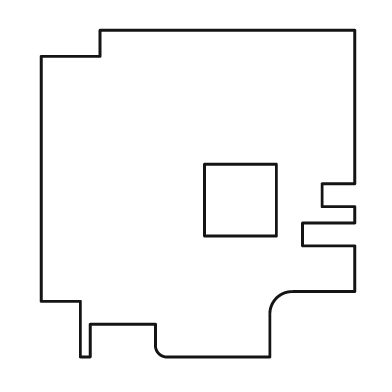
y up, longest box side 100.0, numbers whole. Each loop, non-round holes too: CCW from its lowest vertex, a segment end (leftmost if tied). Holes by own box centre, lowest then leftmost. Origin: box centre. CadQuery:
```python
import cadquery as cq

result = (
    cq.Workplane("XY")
    .moveTo(-36.0, -50.0)
    .lineTo(-33.0, -50.0)
    .lineTo(-33.0, -40.0)
    .lineTo(-13.0, -40.0)
    .lineTo(-13.0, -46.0)
    .threePointArc((-12.0, -49.0), (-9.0, -50.0))
    .lineTo(22.0, -50.0)
    .lineTo(22.0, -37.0)
    .threePointArc((24.0, -32.0), (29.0, -30.0))
    .lineTo(48.0, -30.0)
    .lineTo(48.0, -16.0)
    .lineTo(32.0, -16.0)
    .lineTo(32.0, -9.0)
    .lineTo(48.0, -9.0)
    .lineTo(48.0, -4.0)
    .lineTo(38.0, -4.0)
    .lineTo(38.0, 3.0)
    .lineTo(48.0, 3.0)
    .lineTo(48.0, 50.0)
    .lineTo(-30.0, 50.0)
    .lineTo(-30.0, 42.0)
    .lineTo(-48.0, 42.0)
    .lineTo(-48.0, -33.0)
    .lineTo(-36.0, -33.0)
    .close()
    .moveTo(2.0, -13.0)
    .lineTo(24.0, -13.0)
    .lineTo(24.0, 9.0)
    .lineTo(2.0, 9.0)
    .close()
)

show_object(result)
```